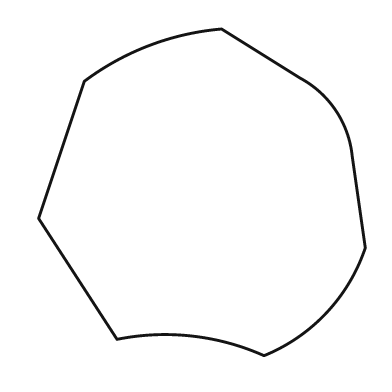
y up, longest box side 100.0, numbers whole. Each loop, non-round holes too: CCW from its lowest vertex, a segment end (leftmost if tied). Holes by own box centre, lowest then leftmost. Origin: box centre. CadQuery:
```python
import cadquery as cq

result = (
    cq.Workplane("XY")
    .moveTo(19.0, -50.0)
    .threePointArc((38.0, -37.0), (50.0, -17.0))
    .lineTo(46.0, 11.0)
    .threePointArc((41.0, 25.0), (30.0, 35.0))
    .lineTo(6.0, 50.0)
    .threePointArc((-16.0, 45.0), (-36.0, 34.0))
    .lineTo(-50.0, -8.0)
    .lineTo(-26.0, -45.0)
    .threePointArc((-3.0, -44.0), (19.0, -50.0))
    .close()
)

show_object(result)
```